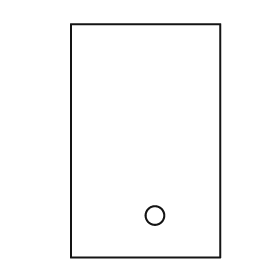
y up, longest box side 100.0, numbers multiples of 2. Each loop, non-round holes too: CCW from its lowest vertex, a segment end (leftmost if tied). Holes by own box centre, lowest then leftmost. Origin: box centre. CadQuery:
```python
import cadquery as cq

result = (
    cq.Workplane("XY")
    .moveTo(-32.0, -50.0)
    .lineTo(32.0, -50.0)
    .lineTo(32.0, 50.0)
    .lineTo(-32.0, 50.0)
    .close()
    .moveTo(4.0, -32.0)
    .circle(4.0)
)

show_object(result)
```